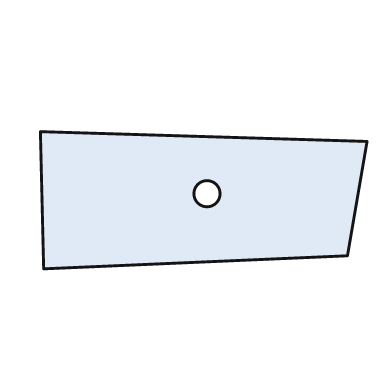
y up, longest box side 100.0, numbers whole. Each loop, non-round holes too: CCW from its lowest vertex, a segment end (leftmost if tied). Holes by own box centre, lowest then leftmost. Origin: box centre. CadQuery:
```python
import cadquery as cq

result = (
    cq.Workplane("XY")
    .moveTo(-49.0, -21.0)
    .lineTo(44.0, -17.0)
    .lineTo(50.0, 18.0)
    .lineTo(-50.0, 21.0)
    .close()
    .moveTo(1.0, 2.0)
    .circle(4.0)
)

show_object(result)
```